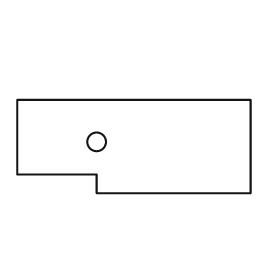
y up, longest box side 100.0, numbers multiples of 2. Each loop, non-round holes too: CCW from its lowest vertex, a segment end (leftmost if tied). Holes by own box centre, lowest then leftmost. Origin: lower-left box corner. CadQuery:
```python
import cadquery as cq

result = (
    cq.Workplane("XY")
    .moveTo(34.0, 0.0)
    .lineTo(100.0, 0.0)
    .lineTo(100.0, 40.0)
    .lineTo(0.0, 40.0)
    .lineTo(0.0, 8.0)
    .lineTo(34.0, 8.0)
    .close()
    .moveTo(34.0, 22.0)
    .circle(4.0)
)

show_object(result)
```